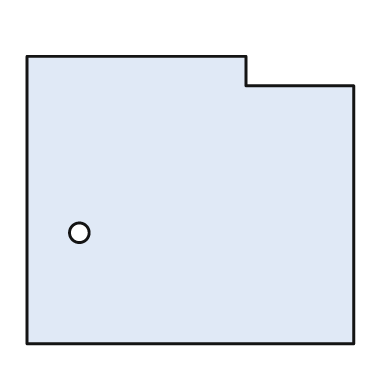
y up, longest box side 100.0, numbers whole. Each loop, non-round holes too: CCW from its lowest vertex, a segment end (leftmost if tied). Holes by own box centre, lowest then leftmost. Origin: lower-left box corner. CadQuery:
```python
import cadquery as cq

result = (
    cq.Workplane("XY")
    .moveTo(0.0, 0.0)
    .lineTo(100.0, 0.0)
    .lineTo(100.0, 79.0)
    .lineTo(67.0, 79.0)
    .lineTo(67.0, 88.0)
    .lineTo(0.0, 88.0)
    .close()
    .moveTo(16.0, 34.0)
    .circle(3.0)
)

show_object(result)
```